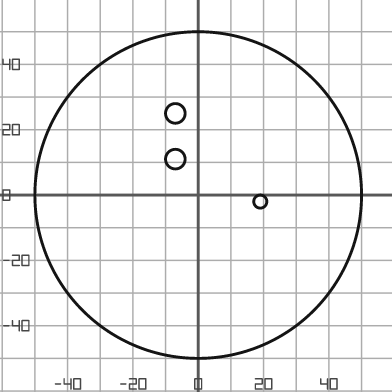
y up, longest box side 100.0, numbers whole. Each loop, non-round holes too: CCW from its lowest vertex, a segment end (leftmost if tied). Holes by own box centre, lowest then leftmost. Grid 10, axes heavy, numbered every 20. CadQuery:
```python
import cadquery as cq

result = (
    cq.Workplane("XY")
    .moveTo(0.0, 0.0)
    .circle(50.0)
    .moveTo(19.0, -2.0)
    .circle(2.0)
    .moveTo(-7.0, 11.0)
    .circle(3.0)
    .moveTo(-7.0, 25.0)
    .circle(3.0)
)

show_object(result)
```